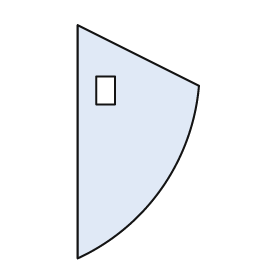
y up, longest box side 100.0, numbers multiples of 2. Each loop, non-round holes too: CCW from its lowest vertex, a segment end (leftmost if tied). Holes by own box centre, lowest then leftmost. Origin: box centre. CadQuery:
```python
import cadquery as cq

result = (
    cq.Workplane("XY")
    .moveTo(-26.0, -50.0)
    .threePointArc((10.0, -20.0), (26.0, 24.0))
    .lineTo(-26.0, 50.0)
    .close()
    .moveTo(-18.0, 16.0)
    .lineTo(-10.0, 16.0)
    .lineTo(-10.0, 28.0)
    .lineTo(-18.0, 28.0)
    .close()
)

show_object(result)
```